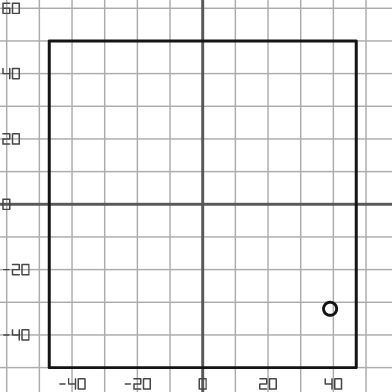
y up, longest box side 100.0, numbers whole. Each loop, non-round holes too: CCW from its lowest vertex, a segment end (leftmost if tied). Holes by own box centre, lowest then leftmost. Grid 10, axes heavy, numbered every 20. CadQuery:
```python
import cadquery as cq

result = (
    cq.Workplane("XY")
    .moveTo(-47.0, -50.0)
    .lineTo(47.0, -50.0)
    .lineTo(47.0, 50.0)
    .lineTo(-47.0, 50.0)
    .close()
    .moveTo(39.0, -32.0)
    .circle(2.0)
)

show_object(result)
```